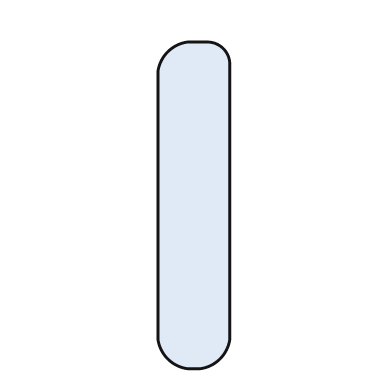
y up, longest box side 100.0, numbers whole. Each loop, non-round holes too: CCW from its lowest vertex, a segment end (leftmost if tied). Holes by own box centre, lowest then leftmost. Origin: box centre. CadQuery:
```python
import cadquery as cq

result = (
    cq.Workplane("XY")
    .moveTo(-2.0, -50.0)
    .lineTo(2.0, -50.0)
    .threePointArc((8.0, -47.0), (11.0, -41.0))
    .lineTo(11.0, 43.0)
    .threePointArc((9.0, 48.0), (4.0, 50.0))
    .lineTo(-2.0, 50.0)
    .threePointArc((-8.0, 47.0), (-11.0, 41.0))
    .lineTo(-11.0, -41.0)
    .threePointArc((-8.0, -47.0), (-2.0, -50.0))
    .close()
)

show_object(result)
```